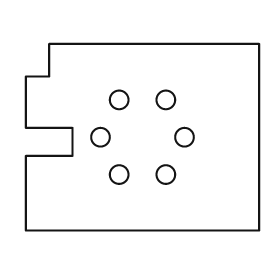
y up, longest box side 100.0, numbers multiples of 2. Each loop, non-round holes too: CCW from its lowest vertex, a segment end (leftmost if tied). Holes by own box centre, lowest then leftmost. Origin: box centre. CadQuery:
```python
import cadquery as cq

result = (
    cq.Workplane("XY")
    .moveTo(-50.0, -40.0)
    .lineTo(50.0, -40.0)
    .lineTo(50.0, 40.0)
    .lineTo(-40.0, 40.0)
    .lineTo(-40.0, 26.0)
    .lineTo(-50.0, 26.0)
    .lineTo(-50.0, 4.0)
    .lineTo(-30.0, 4.0)
    .lineTo(-30.0, -8.0)
    .lineTo(-50.0, -8.0)
    .close()
    .moveTo(-10.0, -16.0)
    .circle(4.0)
    .moveTo(10.0, -16.0)
    .circle(4.0)
    .moveTo(-18.0, 0.0)
    .circle(4.0)
    .moveTo(18.0, 0.0)
    .circle(4.0)
    .moveTo(-10.0, 16.0)
    .circle(4.0)
    .moveTo(10.0, 16.0)
    .circle(4.0)
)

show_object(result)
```